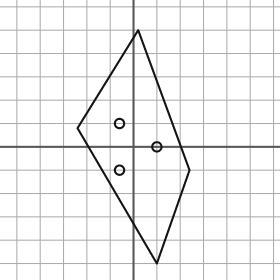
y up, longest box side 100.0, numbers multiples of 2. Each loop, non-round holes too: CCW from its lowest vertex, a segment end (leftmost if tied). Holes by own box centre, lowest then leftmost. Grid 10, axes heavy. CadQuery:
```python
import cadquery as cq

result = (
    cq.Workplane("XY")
    .moveTo(10.0, -50.0)
    .lineTo(24.0, -10.0)
    .lineTo(2.0, 50.0)
    .lineTo(-24.0, 8.0)
    .close()
    .moveTo(-6.0, -10.0)
    .circle(2.0)
    .moveTo(10.0, 0.0)
    .circle(2.0)
    .moveTo(-6.0, 10.0)
    .circle(2.0)
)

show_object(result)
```